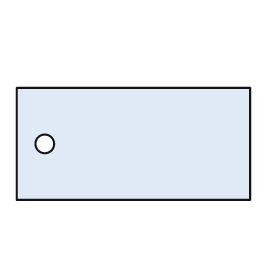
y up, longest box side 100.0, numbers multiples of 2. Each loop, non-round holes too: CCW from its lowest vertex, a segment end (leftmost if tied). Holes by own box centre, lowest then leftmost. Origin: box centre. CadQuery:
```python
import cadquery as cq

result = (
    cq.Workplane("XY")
    .moveTo(-50.0, -24.0)
    .lineTo(50.0, -24.0)
    .lineTo(50.0, 24.0)
    .lineTo(-50.0, 24.0)
    .close()
    .moveTo(-38.0, 0.0)
    .circle(4.0)
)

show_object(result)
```